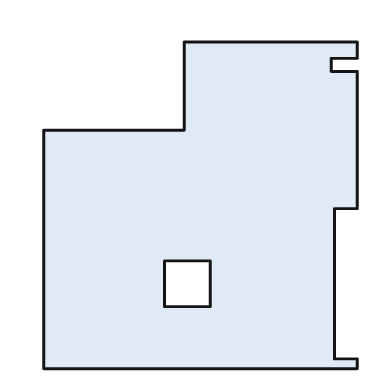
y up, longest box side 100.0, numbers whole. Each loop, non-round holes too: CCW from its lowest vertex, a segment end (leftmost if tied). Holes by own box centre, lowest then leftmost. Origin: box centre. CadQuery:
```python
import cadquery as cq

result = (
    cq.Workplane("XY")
    .moveTo(-48.0, -50.0)
    .lineTo(48.0, -50.0)
    .lineTo(48.0, -47.0)
    .lineTo(41.0, -47.0)
    .lineTo(41.0, -1.0)
    .lineTo(48.0, -1.0)
    .lineTo(48.0, 41.0)
    .lineTo(40.0, 41.0)
    .lineTo(40.0, 45.0)
    .lineTo(48.0, 45.0)
    .lineTo(48.0, 50.0)
    .lineTo(-5.0, 50.0)
    .lineTo(-5.0, 23.0)
    .lineTo(-48.0, 23.0)
    .close()
    .moveTo(-11.0, -31.0)
    .lineTo(3.0, -31.0)
    .lineTo(3.0, -17.0)
    .lineTo(-11.0, -17.0)
    .close()
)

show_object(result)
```